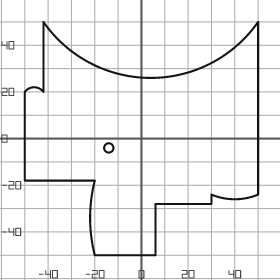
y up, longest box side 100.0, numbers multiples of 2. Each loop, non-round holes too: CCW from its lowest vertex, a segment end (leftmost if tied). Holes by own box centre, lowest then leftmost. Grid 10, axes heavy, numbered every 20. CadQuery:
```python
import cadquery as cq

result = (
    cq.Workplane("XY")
    .moveTo(-20.0, -50.0)
    .lineTo(6.0, -50.0)
    .lineTo(6.0, -28.0)
    .lineTo(30.0, -28.0)
    .lineTo(30.0, -24.0)
    .threePointArc((40.0, -26.0), (50.0, -24.0))
    .lineTo(50.0, 50.0)
    .threePointArc((4.0, 26.0), (-42.0, 50.0))
    .lineTo(-42.0, 20.0)
    .threePointArc((-46.0, 22.0), (-50.0, 20.0))
    .lineTo(-50.0, -18.0)
    .lineTo(-20.0, -18.0)
    .threePointArc((-22.0, -34.0), (-20.0, -50.0))
    .close()
    .moveTo(-14.0, -4.0)
    .circle(2.0)
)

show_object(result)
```